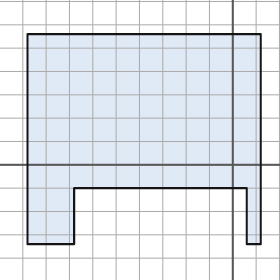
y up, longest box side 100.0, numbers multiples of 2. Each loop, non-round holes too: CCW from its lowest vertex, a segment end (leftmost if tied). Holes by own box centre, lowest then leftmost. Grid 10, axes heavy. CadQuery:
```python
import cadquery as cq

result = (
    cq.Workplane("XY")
    .moveTo(-88.0, -34.0)
    .lineTo(-68.0, -34.0)
    .lineTo(-68.0, -10.0)
    .lineTo(6.0, -10.0)
    .lineTo(6.0, -34.0)
    .lineTo(12.0, -34.0)
    .lineTo(12.0, 56.0)
    .lineTo(-88.0, 56.0)
    .close()
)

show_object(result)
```